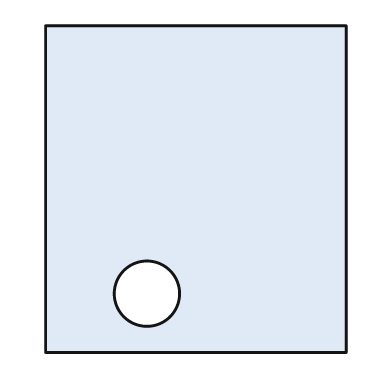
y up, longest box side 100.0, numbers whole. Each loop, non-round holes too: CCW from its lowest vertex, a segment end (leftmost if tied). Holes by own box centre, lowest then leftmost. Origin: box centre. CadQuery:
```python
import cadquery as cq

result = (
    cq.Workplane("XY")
    .moveTo(-46.0, -50.0)
    .lineTo(46.0, -50.0)
    .lineTo(46.0, 50.0)
    .lineTo(-46.0, 50.0)
    .close()
    .moveTo(-15.0, -32.0)
    .circle(10.0)
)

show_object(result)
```